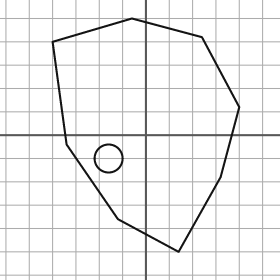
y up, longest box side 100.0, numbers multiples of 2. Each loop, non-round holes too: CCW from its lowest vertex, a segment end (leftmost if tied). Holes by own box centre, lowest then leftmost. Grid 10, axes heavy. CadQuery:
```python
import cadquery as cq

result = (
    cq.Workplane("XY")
    .moveTo(14.0, -50.0)
    .lineTo(32.0, -18.0)
    .lineTo(40.0, 12.0)
    .lineTo(24.0, 42.0)
    .lineTo(-6.0, 50.0)
    .lineTo(-40.0, 40.0)
    .lineTo(-34.0, -4.0)
    .lineTo(-12.0, -36.0)
    .close()
    .moveTo(-16.0, -10.0)
    .circle(6.0)
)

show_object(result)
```